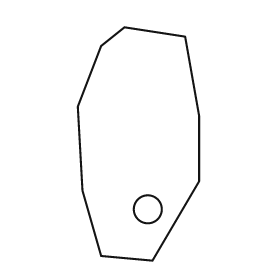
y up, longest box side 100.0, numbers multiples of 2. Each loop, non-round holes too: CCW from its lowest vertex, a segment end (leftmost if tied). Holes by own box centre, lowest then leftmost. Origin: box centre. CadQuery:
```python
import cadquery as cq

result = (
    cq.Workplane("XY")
    .moveTo(6.0, -50.0)
    .lineTo(26.0, -16.0)
    .lineTo(26.0, 12.0)
    .lineTo(20.0, 46.0)
    .lineTo(-6.0, 50.0)
    .lineTo(-16.0, 42.0)
    .lineTo(-26.0, 16.0)
    .lineTo(-24.0, -20.0)
    .lineTo(-16.0, -48.0)
    .close()
    .moveTo(4.0, -28.0)
    .circle(6.0)
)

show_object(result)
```